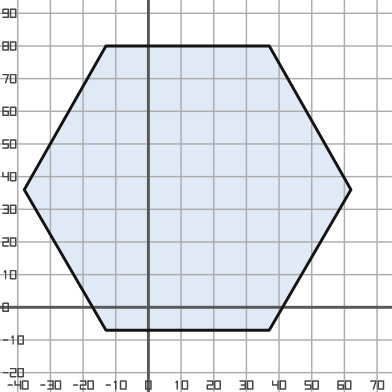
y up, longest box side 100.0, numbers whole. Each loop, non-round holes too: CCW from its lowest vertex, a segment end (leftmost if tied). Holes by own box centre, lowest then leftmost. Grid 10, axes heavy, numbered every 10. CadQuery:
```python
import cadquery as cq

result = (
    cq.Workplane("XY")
    .moveTo(-13.0, -7.0)
    .lineTo(37.0, -7.0)
    .lineTo(62.0, 36.0)
    .lineTo(37.0, 80.0)
    .lineTo(-13.0, 80.0)
    .lineTo(-38.0, 36.0)
    .close()
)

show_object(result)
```